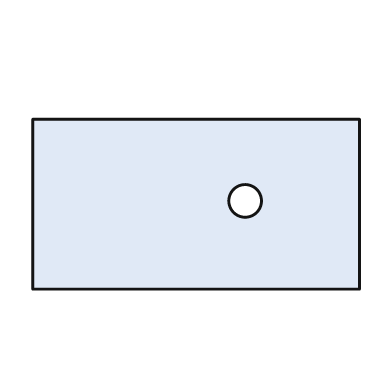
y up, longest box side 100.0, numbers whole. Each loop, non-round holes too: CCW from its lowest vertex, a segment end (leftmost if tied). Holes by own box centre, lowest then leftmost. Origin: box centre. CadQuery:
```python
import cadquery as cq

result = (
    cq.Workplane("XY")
    .moveTo(-50.0, -26.0)
    .lineTo(50.0, -26.0)
    .lineTo(50.0, 26.0)
    .lineTo(-50.0, 26.0)
    .close()
    .moveTo(15.0, 1.0)
    .circle(5.0)
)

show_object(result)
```